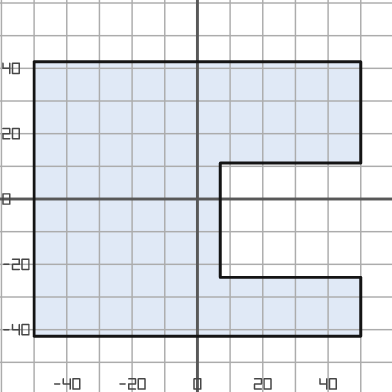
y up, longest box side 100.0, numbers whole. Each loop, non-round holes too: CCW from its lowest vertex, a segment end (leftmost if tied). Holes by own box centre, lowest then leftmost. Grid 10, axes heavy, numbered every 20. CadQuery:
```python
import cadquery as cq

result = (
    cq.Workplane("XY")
    .moveTo(-50.0, -42.0)
    .lineTo(50.0, -42.0)
    .lineTo(50.0, -24.0)
    .lineTo(7.0, -24.0)
    .lineTo(7.0, 11.0)
    .lineTo(50.0, 11.0)
    .lineTo(50.0, 42.0)
    .lineTo(-50.0, 42.0)
    .close()
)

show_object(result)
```